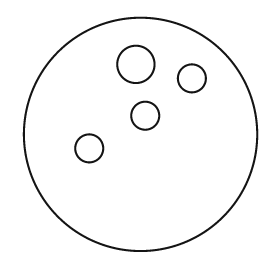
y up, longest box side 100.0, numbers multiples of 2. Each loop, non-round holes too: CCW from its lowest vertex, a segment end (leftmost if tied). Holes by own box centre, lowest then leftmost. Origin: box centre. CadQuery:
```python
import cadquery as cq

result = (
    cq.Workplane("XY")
    .moveTo(0.0, 0.0)
    .circle(50.0)
    .moveTo(-22.0, -6.0)
    .circle(6.0)
    .moveTo(2.0, 8.0)
    .circle(6.0)
    .moveTo(22.0, 24.0)
    .circle(6.0)
    .moveTo(-2.0, 30.0)
    .circle(8.0)
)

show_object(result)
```